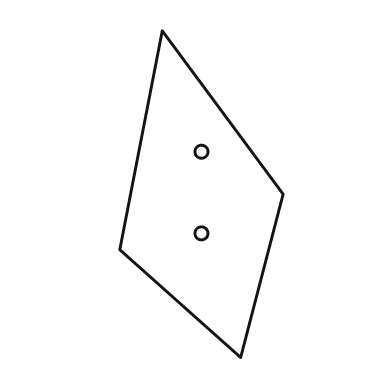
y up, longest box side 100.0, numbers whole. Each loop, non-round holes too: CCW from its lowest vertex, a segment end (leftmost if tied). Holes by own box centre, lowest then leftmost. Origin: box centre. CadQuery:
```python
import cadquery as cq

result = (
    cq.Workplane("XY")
    .moveTo(12.0, -50.0)
    .lineTo(25.0, 0.0)
    .lineTo(-12.0, 50.0)
    .lineTo(-25.0, -17.0)
    .close()
    .moveTo(0.0, -12.0)
    .circle(2.0)
    .moveTo(0.0, 13.0)
    .circle(2.0)
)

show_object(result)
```